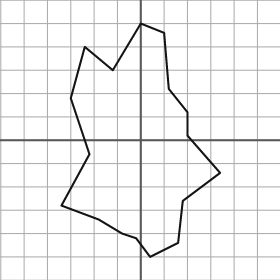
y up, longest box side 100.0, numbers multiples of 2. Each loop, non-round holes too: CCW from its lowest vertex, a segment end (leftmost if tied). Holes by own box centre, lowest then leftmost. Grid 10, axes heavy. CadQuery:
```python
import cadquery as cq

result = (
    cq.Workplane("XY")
    .moveTo(4.0, -50.0)
    .lineTo(16.0, -44.0)
    .lineTo(18.0, -26.0)
    .lineTo(34.0, -14.0)
    .lineTo(20.0, 2.0)
    .lineTo(20.0, 12.0)
    .lineTo(12.0, 22.0)
    .lineTo(10.0, 46.0)
    .lineTo(0.0, 50.0)
    .lineTo(-12.0, 30.0)
    .lineTo(-24.0, 40.0)
    .lineTo(-30.0, 18.0)
    .lineTo(-22.0, -6.0)
    .lineTo(-34.0, -28.0)
    .lineTo(-18.0, -34.0)
    .lineTo(-8.0, -40.0)
    .lineTo(-2.0, -42.0)
    .close()
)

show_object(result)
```